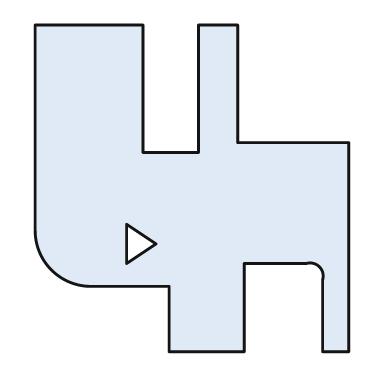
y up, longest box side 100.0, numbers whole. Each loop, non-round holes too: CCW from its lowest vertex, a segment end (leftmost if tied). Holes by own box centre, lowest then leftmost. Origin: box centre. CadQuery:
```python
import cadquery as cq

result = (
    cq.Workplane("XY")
    .moveTo(-7.0, -50.0)
    .lineTo(16.0, -50.0)
    .lineTo(16.0, -23.0)
    .lineTo(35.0, -23.0)
    .threePointArc((39.0, -24.0), (40.0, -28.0))
    .lineTo(40.0, -50.0)
    .lineTo(48.0, -50.0)
    .lineTo(48.0, 14.0)
    .lineTo(14.0, 14.0)
    .lineTo(14.0, 50.0)
    .lineTo(2.0, 50.0)
    .lineTo(2.0, 11.0)
    .lineTo(-15.0, 11.0)
    .lineTo(-15.0, 50.0)
    .lineTo(-48.0, 50.0)
    .lineTo(-48.0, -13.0)
    .threePointArc((-43.0, -25.0), (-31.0, -30.0))
    .lineTo(-7.0, -30.0)
    .close()
    .moveTo(-20.0, -23.0)
    .lineTo(-11.0, -17.0)
    .lineTo(-20.0, -11.0)
    .close()
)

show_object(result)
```